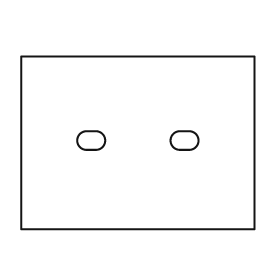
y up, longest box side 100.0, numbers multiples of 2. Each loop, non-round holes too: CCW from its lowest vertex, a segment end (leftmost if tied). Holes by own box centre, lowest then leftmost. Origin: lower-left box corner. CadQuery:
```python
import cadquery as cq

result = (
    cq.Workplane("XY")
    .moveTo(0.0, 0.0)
    .lineTo(100.0, 0.0)
    .lineTo(100.0, 74.0)
    .lineTo(0.0, 74.0)
    .close()
    .moveTo(28.0, 34.0)
    .lineTo(32.0, 34.0)
    .threePointArc((36.0, 38.0), (32.0, 42.0))
    .lineTo(28.0, 42.0)
    .threePointArc((24.0, 38.0), (28.0, 34.0))
    .close()
    .moveTo(68.0, 34.0)
    .lineTo(72.0, 34.0)
    .threePointArc((76.0, 38.0), (72.0, 42.0))
    .lineTo(68.0, 42.0)
    .threePointArc((64.0, 38.0), (68.0, 34.0))
    .close()
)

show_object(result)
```